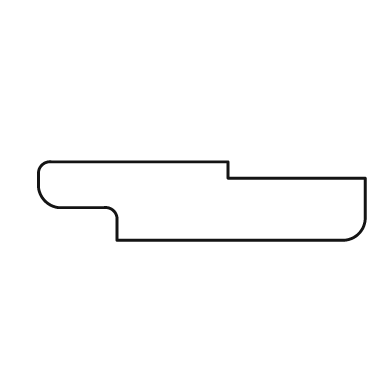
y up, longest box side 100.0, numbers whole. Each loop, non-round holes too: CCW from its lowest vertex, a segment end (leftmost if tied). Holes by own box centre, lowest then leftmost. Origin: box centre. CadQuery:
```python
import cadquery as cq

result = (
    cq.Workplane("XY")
    .moveTo(-26.0, -12.0)
    .lineTo(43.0, -12.0)
    .threePointArc((48.0, -10.0), (50.0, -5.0))
    .lineTo(50.0, 7.0)
    .lineTo(8.0, 7.0)
    .lineTo(8.0, 12.0)
    .lineTo(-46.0, 12.0)
    .threePointArc((-49.0, 11.0), (-50.0, 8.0))
    .lineTo(-50.0, 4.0)
    .threePointArc((-48.0, 0.0), (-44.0, -2.0))
    .lineTo(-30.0, -2.0)
    .threePointArc((-27.0, -3.0), (-26.0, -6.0))
    .close()
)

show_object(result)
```